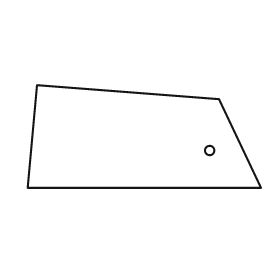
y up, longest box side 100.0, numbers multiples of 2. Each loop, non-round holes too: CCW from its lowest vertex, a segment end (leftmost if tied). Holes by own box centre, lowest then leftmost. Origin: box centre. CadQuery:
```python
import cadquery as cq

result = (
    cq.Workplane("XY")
    .moveTo(-50.0, -22.0)
    .lineTo(50.0, -22.0)
    .lineTo(32.0, 16.0)
    .lineTo(-46.0, 22.0)
    .close()
    .moveTo(28.0, -6.0)
    .circle(2.0)
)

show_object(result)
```